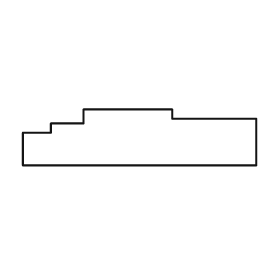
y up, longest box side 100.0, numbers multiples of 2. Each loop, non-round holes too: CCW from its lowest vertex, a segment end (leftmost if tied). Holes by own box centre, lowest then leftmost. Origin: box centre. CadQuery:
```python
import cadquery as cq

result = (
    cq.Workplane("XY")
    .moveTo(-50.0, -12.0)
    .lineTo(50.0, -12.0)
    .lineTo(50.0, 8.0)
    .lineTo(14.0, 8.0)
    .lineTo(14.0, 12.0)
    .lineTo(-24.0, 12.0)
    .lineTo(-24.0, 6.0)
    .lineTo(-38.0, 6.0)
    .lineTo(-38.0, 2.0)
    .lineTo(-50.0, 2.0)
    .close()
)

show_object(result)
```